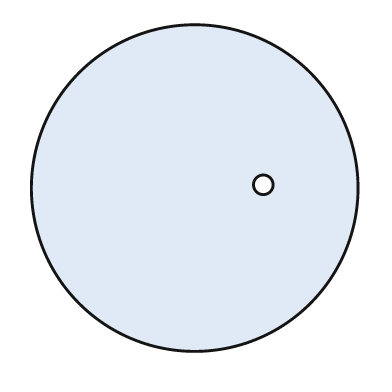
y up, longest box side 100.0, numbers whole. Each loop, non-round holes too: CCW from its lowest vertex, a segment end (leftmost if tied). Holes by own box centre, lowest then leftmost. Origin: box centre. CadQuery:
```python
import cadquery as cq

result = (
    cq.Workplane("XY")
    .moveTo(0.0, 0.0)
    .circle(50.0)
    .moveTo(21.0, 1.0)
    .circle(3.0)
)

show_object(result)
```